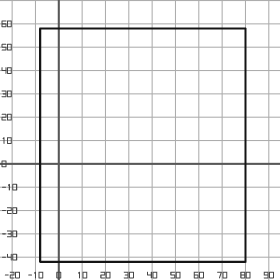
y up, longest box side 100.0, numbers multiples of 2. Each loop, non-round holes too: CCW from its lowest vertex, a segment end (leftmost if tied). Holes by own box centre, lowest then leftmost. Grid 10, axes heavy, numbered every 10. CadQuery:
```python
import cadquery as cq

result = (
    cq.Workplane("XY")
    .moveTo(-8.0, -42.0)
    .lineTo(80.0, -42.0)
    .lineTo(80.0, 58.0)
    .lineTo(-8.0, 58.0)
    .close()
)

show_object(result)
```